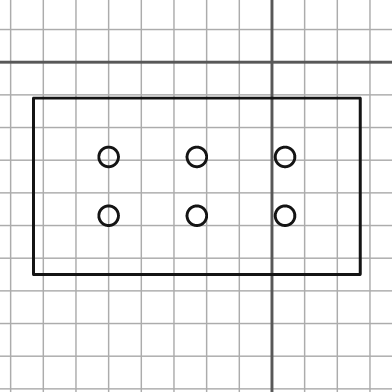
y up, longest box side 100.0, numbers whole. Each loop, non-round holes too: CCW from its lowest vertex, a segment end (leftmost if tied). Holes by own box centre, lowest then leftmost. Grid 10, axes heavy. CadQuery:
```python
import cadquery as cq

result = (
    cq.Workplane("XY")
    .moveTo(-73.0, -65.0)
    .lineTo(27.0, -65.0)
    .lineTo(27.0, -11.0)
    .lineTo(-73.0, -11.0)
    .close()
    .moveTo(-50.0, -47.0)
    .circle(3.0)
    .moveTo(-23.0, -47.0)
    .circle(3.0)
    .moveTo(4.0, -47.0)
    .circle(3.0)
    .moveTo(-50.0, -29.0)
    .circle(3.0)
    .moveTo(-23.0, -29.0)
    .circle(3.0)
    .moveTo(4.0, -29.0)
    .circle(3.0)
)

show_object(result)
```